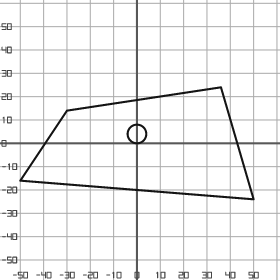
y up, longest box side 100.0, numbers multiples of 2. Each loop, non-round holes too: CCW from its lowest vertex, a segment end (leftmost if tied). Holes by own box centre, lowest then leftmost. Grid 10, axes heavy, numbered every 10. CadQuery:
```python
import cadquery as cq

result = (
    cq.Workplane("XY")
    .moveTo(50.0, -24.0)
    .lineTo(36.0, 24.0)
    .lineTo(-30.0, 14.0)
    .lineTo(-50.0, -16.0)
    .close()
    .moveTo(0.0, 4.0)
    .circle(4.0)
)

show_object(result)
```